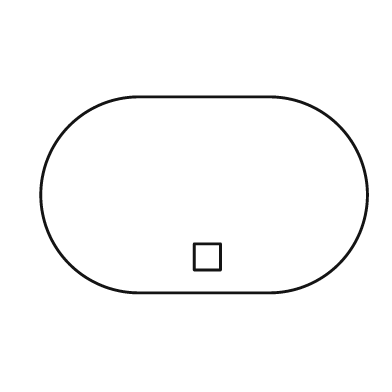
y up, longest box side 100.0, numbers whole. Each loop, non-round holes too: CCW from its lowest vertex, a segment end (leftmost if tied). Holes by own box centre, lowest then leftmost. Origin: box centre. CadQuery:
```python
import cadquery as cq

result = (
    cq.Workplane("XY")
    .moveTo(-20.0, -30.0)
    .lineTo(20.0, -30.0)
    .threePointArc((50.0, 0.0), (20.0, 30.0))
    .lineTo(-20.0, 30.0)
    .threePointArc((-50.0, 0.0), (-20.0, -30.0))
    .close()
    .moveTo(-3.0, -23.0)
    .lineTo(5.0, -23.0)
    .lineTo(5.0, -15.0)
    .lineTo(-3.0, -15.0)
    .close()
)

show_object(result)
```